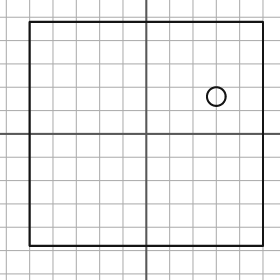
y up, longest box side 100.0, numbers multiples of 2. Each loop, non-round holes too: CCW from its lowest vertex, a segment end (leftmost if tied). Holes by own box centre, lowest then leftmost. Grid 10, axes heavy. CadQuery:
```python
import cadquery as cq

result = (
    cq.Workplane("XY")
    .moveTo(-50.0, -48.0)
    .lineTo(50.0, -48.0)
    .lineTo(50.0, 48.0)
    .lineTo(-50.0, 48.0)
    .close()
    .moveTo(30.0, 16.0)
    .circle(4.0)
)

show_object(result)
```